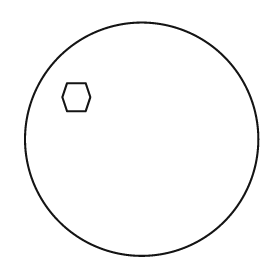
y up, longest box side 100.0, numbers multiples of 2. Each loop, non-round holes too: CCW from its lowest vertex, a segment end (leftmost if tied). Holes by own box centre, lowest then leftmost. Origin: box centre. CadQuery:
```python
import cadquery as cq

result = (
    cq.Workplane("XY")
    .moveTo(0.0, 0.0)
    .circle(50.0)
    .moveTo(-32.0, 12.0)
    .lineTo(-24.0, 12.0)
    .lineTo(-22.0, 18.0)
    .lineTo(-24.0, 24.0)
    .lineTo(-32.0, 24.0)
    .lineTo(-34.0, 18.0)
    .close()
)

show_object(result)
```